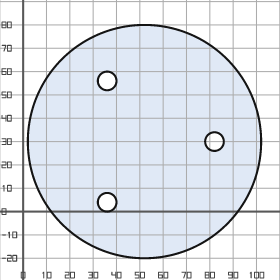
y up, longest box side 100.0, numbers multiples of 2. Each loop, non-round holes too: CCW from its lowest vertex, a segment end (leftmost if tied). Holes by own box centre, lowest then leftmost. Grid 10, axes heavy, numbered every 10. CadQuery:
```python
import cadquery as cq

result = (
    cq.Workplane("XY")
    .moveTo(52.0, 30.0)
    .circle(50.0)
    .moveTo(36.0, 4.0)
    .circle(4.0)
    .moveTo(82.0, 30.0)
    .circle(4.0)
    .moveTo(36.0, 56.0)
    .circle(4.0)
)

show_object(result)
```